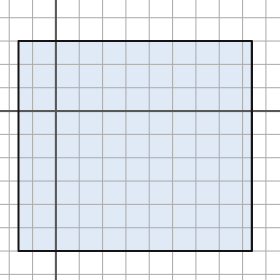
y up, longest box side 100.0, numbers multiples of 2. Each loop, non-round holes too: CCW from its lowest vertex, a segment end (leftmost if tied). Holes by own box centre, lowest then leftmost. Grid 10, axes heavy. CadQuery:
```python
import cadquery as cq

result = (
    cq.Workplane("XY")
    .moveTo(-16.0, -60.0)
    .lineTo(84.0, -60.0)
    .lineTo(84.0, 30.0)
    .lineTo(-16.0, 30.0)
    .close()
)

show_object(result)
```